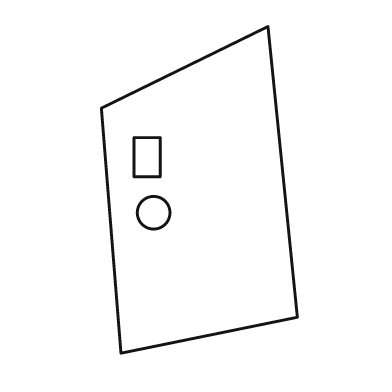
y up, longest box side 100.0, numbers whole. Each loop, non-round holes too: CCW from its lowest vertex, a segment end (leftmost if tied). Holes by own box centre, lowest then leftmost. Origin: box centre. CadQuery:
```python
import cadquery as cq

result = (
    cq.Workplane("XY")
    .moveTo(-24.0, -50.0)
    .lineTo(30.0, -39.0)
    .lineTo(21.0, 50.0)
    .lineTo(-30.0, 25.0)
    .close()
    .moveTo(-14.0, -7.0)
    .circle(5.0)
    .moveTo(-20.0, 4.0)
    .lineTo(-12.0, 4.0)
    .lineTo(-12.0, 16.0)
    .lineTo(-20.0, 16.0)
    .close()
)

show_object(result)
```